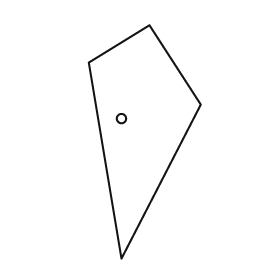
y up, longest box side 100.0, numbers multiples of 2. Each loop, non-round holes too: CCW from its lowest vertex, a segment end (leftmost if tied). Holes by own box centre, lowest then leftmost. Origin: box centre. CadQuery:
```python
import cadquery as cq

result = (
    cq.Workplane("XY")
    .moveTo(-10.0, -50.0)
    .lineTo(24.0, 16.0)
    .lineTo(2.0, 50.0)
    .lineTo(-24.0, 34.0)
    .close()
    .moveTo(-10.0, 10.0)
    .circle(2.0)
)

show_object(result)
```